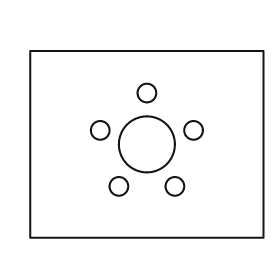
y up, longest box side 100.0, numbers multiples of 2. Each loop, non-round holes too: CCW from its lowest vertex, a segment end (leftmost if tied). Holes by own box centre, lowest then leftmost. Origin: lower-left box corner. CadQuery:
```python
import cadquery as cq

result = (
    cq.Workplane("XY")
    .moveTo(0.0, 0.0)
    .lineTo(100.0, 0.0)
    .lineTo(100.0, 80.0)
    .lineTo(0.0, 80.0)
    .close()
    .moveTo(38.0, 22.0)
    .circle(4.0)
    .moveTo(62.0, 22.0)
    .circle(4.0)
    .moveTo(50.0, 40.0)
    .circle(12.0)
    .moveTo(30.0, 46.0)
    .circle(4.0)
    .moveTo(70.0, 46.0)
    .circle(4.0)
    .moveTo(50.0, 62.0)
    .circle(4.0)
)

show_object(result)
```